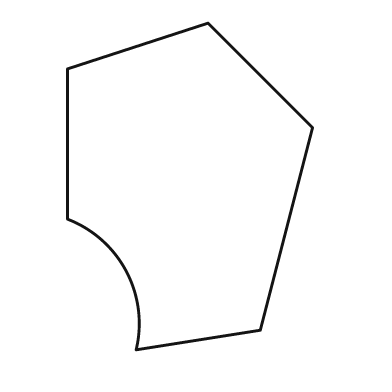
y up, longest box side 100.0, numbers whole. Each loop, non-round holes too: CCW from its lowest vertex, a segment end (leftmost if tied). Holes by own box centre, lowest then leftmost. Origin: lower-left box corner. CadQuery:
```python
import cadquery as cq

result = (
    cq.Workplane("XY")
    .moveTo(21.0, 0.0)
    .lineTo(59.0, 6.0)
    .lineTo(75.0, 68.0)
    .lineTo(43.0, 100.0)
    .lineTo(0.0, 86.0)
    .lineTo(0.0, 40.0)
    .threePointArc((18.0, 24.0), (21.0, 0.0))
    .close()
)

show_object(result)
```